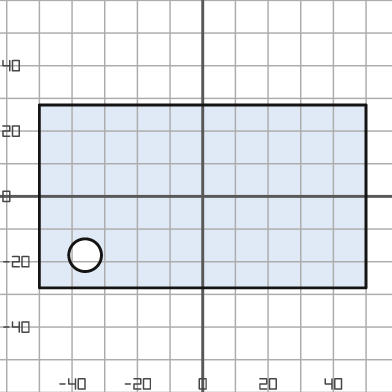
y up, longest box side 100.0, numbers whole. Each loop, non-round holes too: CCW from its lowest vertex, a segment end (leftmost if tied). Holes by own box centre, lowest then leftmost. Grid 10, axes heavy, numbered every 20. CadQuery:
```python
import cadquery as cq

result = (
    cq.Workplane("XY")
    .moveTo(-50.0, -28.0)
    .lineTo(50.0, -28.0)
    .lineTo(50.0, 28.0)
    .lineTo(-50.0, 28.0)
    .close()
    .moveTo(-36.0, -18.0)
    .circle(5.0)
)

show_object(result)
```